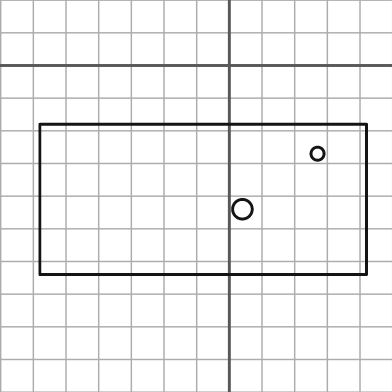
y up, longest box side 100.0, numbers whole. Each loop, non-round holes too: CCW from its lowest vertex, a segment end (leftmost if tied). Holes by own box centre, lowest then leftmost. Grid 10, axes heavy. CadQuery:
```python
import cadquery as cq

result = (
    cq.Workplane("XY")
    .moveTo(-58.0, -64.0)
    .lineTo(42.0, -64.0)
    .lineTo(42.0, -18.0)
    .lineTo(-58.0, -18.0)
    .close()
    .moveTo(4.0, -44.0)
    .circle(3.0)
    .moveTo(27.0, -27.0)
    .circle(2.0)
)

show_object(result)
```